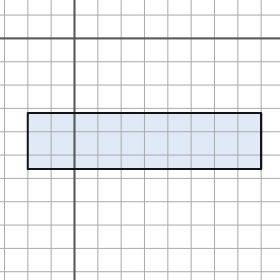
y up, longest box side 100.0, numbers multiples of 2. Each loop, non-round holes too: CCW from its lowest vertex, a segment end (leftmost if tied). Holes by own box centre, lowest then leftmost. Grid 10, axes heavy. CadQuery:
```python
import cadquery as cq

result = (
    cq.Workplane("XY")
    .moveTo(-20.0, -56.0)
    .lineTo(80.0, -56.0)
    .lineTo(80.0, -32.0)
    .lineTo(-20.0, -32.0)
    .close()
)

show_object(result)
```